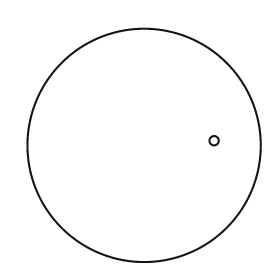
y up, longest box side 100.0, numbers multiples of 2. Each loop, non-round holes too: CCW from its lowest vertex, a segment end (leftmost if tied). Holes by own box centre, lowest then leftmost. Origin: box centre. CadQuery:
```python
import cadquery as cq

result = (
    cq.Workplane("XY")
    .moveTo(0.0, 0.0)
    .circle(50.0)
    .moveTo(30.0, 2.0)
    .circle(2.0)
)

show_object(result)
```